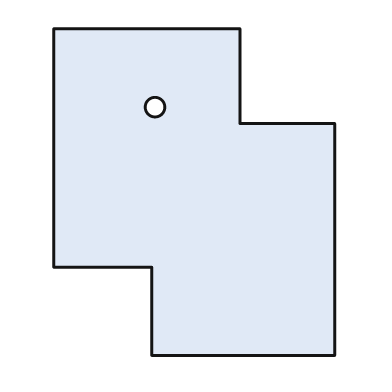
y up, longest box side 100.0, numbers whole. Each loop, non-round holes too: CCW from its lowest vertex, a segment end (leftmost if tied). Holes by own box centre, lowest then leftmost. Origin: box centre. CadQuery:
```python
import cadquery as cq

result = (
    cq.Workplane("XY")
    .moveTo(-13.0, -50.0)
    .lineTo(43.0, -50.0)
    .lineTo(43.0, 21.0)
    .lineTo(14.0, 21.0)
    .lineTo(14.0, 50.0)
    .lineTo(-43.0, 50.0)
    .lineTo(-43.0, -23.0)
    .lineTo(-13.0, -23.0)
    .close()
    .moveTo(-12.0, 26.0)
    .circle(3.0)
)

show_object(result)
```